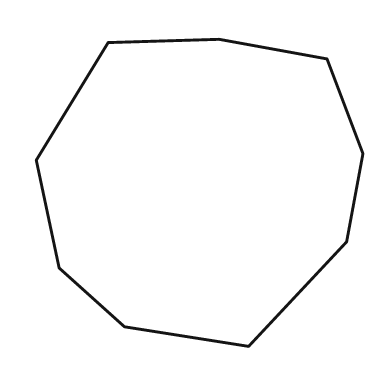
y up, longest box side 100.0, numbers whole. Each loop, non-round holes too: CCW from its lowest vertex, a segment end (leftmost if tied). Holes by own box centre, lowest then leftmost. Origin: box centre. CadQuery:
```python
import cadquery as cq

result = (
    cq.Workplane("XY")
    .moveTo(15.0, -47.0)
    .lineTo(45.0, -15.0)
    .lineTo(50.0, 12.0)
    .lineTo(39.0, 41.0)
    .lineTo(6.0, 47.0)
    .lineTo(-28.0, 46.0)
    .lineTo(-50.0, 10.0)
    .lineTo(-43.0, -23.0)
    .lineTo(-23.0, -41.0)
    .close()
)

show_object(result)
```